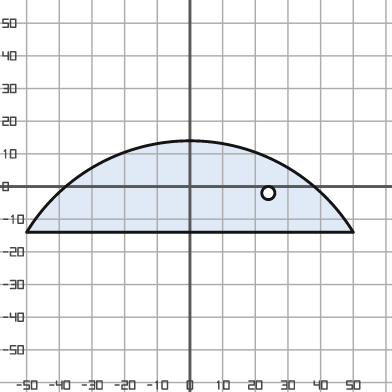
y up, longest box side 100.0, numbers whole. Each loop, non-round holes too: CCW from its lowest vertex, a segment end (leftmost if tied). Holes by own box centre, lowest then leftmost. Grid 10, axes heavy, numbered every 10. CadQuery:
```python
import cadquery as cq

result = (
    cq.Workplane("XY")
    .moveTo(-50.0, -14.0)
    .lineTo(50.0, -14.0)
    .threePointArc((0.0, 14.0), (-50.0, -14.0))
    .close()
    .moveTo(24.0, -2.0)
    .circle(2.0)
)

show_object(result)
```